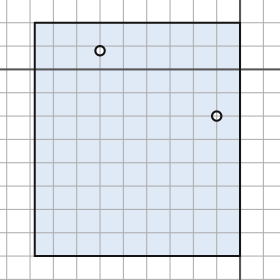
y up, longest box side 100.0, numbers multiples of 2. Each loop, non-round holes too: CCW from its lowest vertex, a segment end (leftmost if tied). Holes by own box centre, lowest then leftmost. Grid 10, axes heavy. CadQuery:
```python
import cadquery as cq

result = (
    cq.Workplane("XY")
    .moveTo(-88.0, -80.0)
    .lineTo(0.0, -80.0)
    .lineTo(0.0, 20.0)
    .lineTo(-88.0, 20.0)
    .close()
    .moveTo(-10.0, -20.0)
    .circle(2.0)
    .moveTo(-60.0, 8.0)
    .circle(2.0)
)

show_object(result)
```